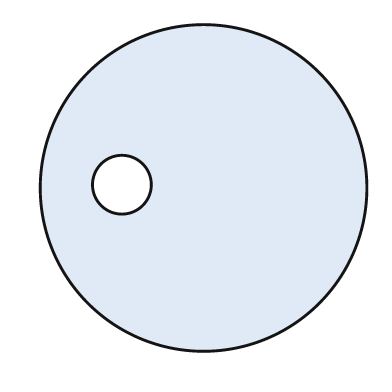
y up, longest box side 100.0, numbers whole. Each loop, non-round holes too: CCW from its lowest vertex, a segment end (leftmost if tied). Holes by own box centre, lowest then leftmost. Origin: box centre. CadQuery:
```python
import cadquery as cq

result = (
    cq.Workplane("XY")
    .moveTo(0.0, 0.0)
    .circle(50.0)
    .moveTo(-25.0, 1.0)
    .circle(9.0)
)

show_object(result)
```